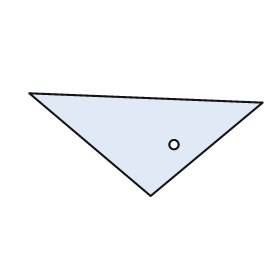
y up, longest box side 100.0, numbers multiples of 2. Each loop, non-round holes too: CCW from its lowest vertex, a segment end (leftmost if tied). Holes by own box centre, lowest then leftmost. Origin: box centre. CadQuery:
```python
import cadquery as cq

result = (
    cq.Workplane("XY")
    .moveTo(2.0, -22.0)
    .lineTo(50.0, 18.0)
    .lineTo(-50.0, 22.0)
    .close()
    .moveTo(12.0, 0.0)
    .circle(2.0)
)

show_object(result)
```